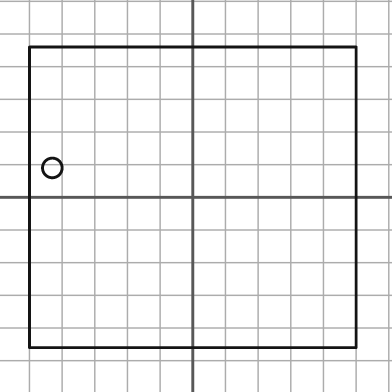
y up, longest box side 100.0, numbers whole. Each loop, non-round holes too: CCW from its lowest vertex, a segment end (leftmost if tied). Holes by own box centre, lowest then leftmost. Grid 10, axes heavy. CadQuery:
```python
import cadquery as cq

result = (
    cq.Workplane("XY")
    .moveTo(-50.0, -46.0)
    .lineTo(50.0, -46.0)
    .lineTo(50.0, 46.0)
    .lineTo(-50.0, 46.0)
    .close()
    .moveTo(-43.0, 9.0)
    .circle(3.0)
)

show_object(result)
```